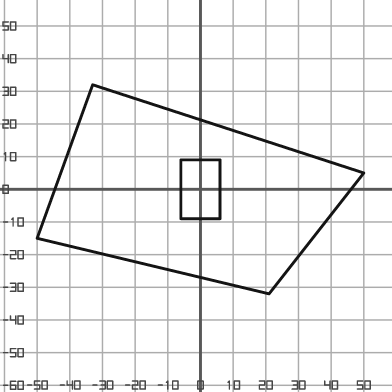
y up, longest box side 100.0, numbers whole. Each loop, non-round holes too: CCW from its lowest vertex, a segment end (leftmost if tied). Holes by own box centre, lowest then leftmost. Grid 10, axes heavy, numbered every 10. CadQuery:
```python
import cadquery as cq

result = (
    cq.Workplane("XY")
    .moveTo(21.0, -32.0)
    .lineTo(50.0, 5.0)
    .lineTo(-33.0, 32.0)
    .lineTo(-50.0, -15.0)
    .close()
    .moveTo(-6.0, -9.0)
    .lineTo(6.0, -9.0)
    .lineTo(6.0, 9.0)
    .lineTo(-6.0, 9.0)
    .close()
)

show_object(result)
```